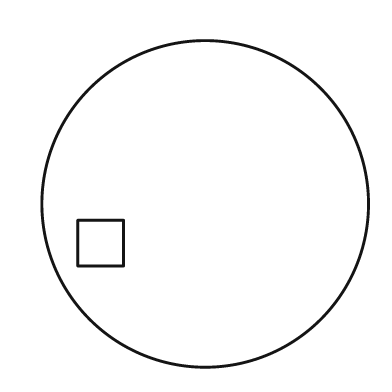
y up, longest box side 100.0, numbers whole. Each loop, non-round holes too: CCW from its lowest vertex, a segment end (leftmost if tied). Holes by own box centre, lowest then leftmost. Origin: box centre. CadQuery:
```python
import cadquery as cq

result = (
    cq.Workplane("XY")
    .moveTo(0.0, 0.0)
    .circle(50.0)
    .moveTo(-39.0, -19.0)
    .lineTo(-25.0, -19.0)
    .lineTo(-25.0, -5.0)
    .lineTo(-39.0, -5.0)
    .close()
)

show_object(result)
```